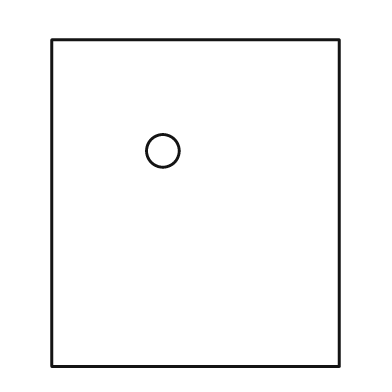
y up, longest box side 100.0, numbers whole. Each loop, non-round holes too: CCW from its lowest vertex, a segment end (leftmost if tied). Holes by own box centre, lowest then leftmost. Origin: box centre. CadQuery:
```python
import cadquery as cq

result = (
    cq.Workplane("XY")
    .moveTo(-44.0, -50.0)
    .lineTo(44.0, -50.0)
    .lineTo(44.0, 50.0)
    .lineTo(-44.0, 50.0)
    .close()
    .moveTo(-10.0, 16.0)
    .circle(5.0)
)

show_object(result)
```